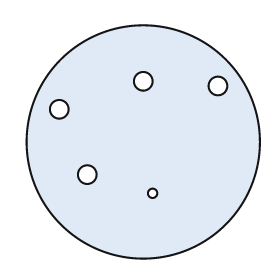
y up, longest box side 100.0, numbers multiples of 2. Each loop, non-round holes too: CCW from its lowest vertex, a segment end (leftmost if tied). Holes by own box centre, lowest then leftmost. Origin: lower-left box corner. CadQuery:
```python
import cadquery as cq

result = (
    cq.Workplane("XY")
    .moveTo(50.0, 50.0)
    .circle(50.0)
    .moveTo(54.0, 28.0)
    .circle(2.0)
    .moveTo(26.0, 36.0)
    .circle(4.0)
    .moveTo(14.0, 64.0)
    .circle(4.0)
    .moveTo(82.0, 74.0)
    .circle(4.0)
    .moveTo(50.0, 76.0)
    .circle(4.0)
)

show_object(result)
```